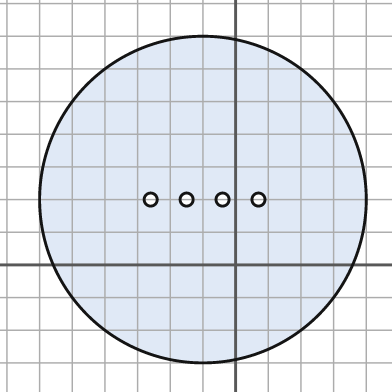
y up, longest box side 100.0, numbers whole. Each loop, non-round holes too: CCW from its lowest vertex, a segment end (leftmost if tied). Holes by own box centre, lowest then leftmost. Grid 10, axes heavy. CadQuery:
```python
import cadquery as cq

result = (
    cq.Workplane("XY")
    .moveTo(-10.0, 20.0)
    .circle(50.0)
    .moveTo(-26.0, 20.0)
    .circle(2.0)
    .moveTo(-15.0, 20.0)
    .circle(2.0)
    .moveTo(-4.0, 20.0)
    .circle(2.0)
    .moveTo(7.0, 20.0)
    .circle(2.0)
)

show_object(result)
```